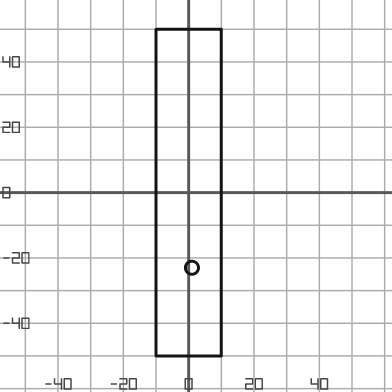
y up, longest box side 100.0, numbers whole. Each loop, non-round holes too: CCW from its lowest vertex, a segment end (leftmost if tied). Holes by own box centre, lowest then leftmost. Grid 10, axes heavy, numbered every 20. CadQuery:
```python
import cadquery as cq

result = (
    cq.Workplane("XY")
    .moveTo(-10.0, -50.0)
    .lineTo(10.0, -50.0)
    .lineTo(10.0, 50.0)
    .lineTo(-10.0, 50.0)
    .close()
    .moveTo(1.0, -23.0)
    .circle(2.0)
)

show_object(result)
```